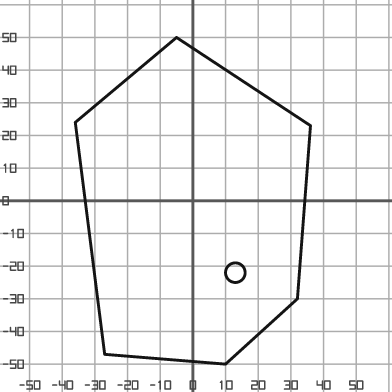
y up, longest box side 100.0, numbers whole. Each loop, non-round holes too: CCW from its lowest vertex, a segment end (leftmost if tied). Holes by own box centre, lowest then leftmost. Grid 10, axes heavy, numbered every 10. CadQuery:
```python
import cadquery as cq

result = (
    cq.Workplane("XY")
    .moveTo(10.0, -50.0)
    .lineTo(32.0, -30.0)
    .lineTo(36.0, 23.0)
    .lineTo(-5.0, 50.0)
    .lineTo(-36.0, 24.0)
    .lineTo(-27.0, -47.0)
    .close()
    .moveTo(13.0, -22.0)
    .circle(3.0)
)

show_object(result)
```